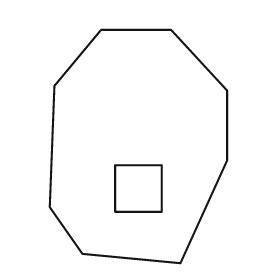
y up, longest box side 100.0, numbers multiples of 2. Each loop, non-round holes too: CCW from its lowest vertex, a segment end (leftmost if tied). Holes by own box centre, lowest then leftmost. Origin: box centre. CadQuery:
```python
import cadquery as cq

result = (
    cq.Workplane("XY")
    .moveTo(18.0, -50.0)
    .lineTo(38.0, -6.0)
    .lineTo(38.0, 24.0)
    .lineTo(14.0, 50.0)
    .lineTo(-16.0, 50.0)
    .lineTo(-36.0, 26.0)
    .lineTo(-38.0, -26.0)
    .lineTo(-24.0, -46.0)
    .close()
    .moveTo(-10.0, -28.0)
    .lineTo(10.0, -28.0)
    .lineTo(10.0, -8.0)
    .lineTo(-10.0, -8.0)
    .close()
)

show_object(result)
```